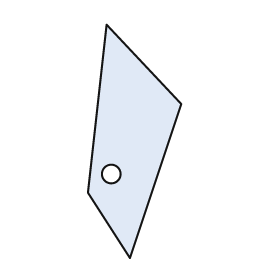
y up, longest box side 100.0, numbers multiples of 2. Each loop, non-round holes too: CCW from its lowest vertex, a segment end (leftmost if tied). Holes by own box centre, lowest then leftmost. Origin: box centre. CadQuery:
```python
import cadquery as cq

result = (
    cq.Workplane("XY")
    .moveTo(-2.0, -50.0)
    .lineTo(20.0, 16.0)
    .lineTo(-12.0, 50.0)
    .lineTo(-20.0, -22.0)
    .close()
    .moveTo(-10.0, -14.0)
    .circle(4.0)
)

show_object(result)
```